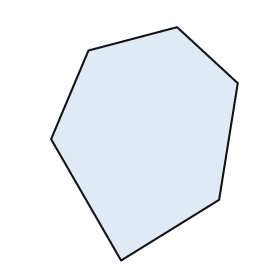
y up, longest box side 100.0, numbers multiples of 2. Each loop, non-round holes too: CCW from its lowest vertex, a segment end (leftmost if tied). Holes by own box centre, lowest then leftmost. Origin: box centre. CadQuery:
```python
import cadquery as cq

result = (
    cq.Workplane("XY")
    .moveTo(-10.0, -50.0)
    .lineTo(32.0, -24.0)
    .lineTo(40.0, 26.0)
    .lineTo(14.0, 50.0)
    .lineTo(-24.0, 40.0)
    .lineTo(-40.0, 2.0)
    .close()
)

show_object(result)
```